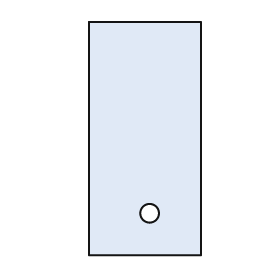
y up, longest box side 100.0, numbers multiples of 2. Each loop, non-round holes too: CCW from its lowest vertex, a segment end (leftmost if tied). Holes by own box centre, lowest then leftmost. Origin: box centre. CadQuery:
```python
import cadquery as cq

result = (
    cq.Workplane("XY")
    .moveTo(-24.0, -50.0)
    .lineTo(24.0, -50.0)
    .lineTo(24.0, 50.0)
    .lineTo(-24.0, 50.0)
    .close()
    .moveTo(2.0, -32.0)
    .circle(4.0)
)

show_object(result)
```